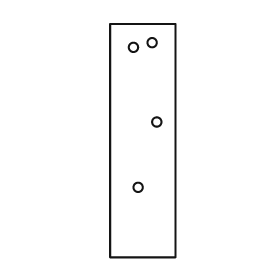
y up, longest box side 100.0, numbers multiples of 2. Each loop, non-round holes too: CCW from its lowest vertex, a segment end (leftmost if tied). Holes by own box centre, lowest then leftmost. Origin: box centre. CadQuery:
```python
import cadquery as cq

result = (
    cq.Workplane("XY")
    .moveTo(-14.0, -50.0)
    .lineTo(14.0, -50.0)
    .lineTo(14.0, 50.0)
    .lineTo(-14.0, 50.0)
    .close()
    .moveTo(-2.0, -20.0)
    .circle(2.0)
    .moveTo(6.0, 8.0)
    .circle(2.0)
    .moveTo(-4.0, 40.0)
    .circle(2.0)
    .moveTo(4.0, 42.0)
    .circle(2.0)
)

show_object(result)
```